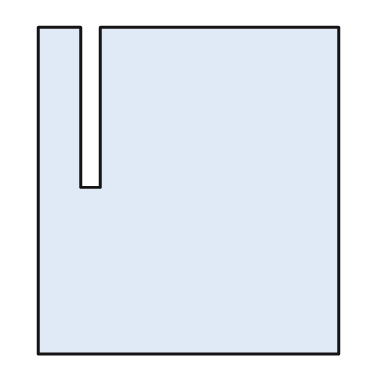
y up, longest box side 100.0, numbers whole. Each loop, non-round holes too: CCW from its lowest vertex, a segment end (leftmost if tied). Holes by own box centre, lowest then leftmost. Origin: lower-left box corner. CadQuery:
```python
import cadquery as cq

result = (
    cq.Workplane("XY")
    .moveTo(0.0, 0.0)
    .lineTo(92.0, 0.0)
    .lineTo(92.0, 100.0)
    .lineTo(19.0, 100.0)
    .lineTo(19.0, 51.0)
    .lineTo(13.0, 51.0)
    .lineTo(13.0, 100.0)
    .lineTo(0.0, 100.0)
    .close()
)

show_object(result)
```